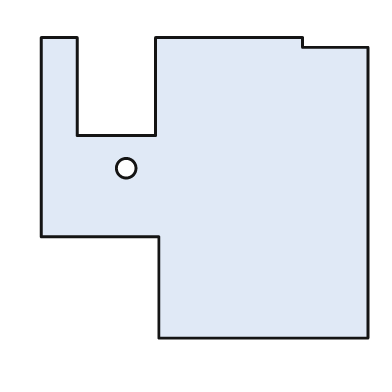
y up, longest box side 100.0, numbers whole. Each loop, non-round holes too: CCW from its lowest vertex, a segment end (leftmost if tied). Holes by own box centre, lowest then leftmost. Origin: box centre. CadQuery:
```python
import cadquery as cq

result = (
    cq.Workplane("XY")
    .moveTo(-14.0, -46.0)
    .lineTo(50.0, -46.0)
    .lineTo(50.0, 43.0)
    .lineTo(30.0, 43.0)
    .lineTo(30.0, 46.0)
    .lineTo(-15.0, 46.0)
    .lineTo(-15.0, 16.0)
    .lineTo(-39.0, 16.0)
    .lineTo(-39.0, 46.0)
    .lineTo(-50.0, 46.0)
    .lineTo(-50.0, -15.0)
    .lineTo(-14.0, -15.0)
    .close()
    .moveTo(-24.0, 6.0)
    .circle(3.0)
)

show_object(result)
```